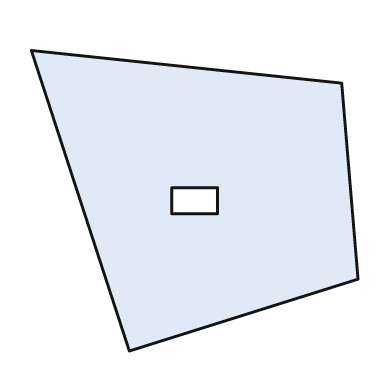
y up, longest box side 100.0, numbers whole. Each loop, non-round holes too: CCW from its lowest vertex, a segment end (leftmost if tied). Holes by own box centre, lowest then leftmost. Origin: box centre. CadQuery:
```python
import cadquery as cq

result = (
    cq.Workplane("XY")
    .moveTo(-20.0, -46.0)
    .lineTo(50.0, -24.0)
    .lineTo(45.0, 36.0)
    .lineTo(-50.0, 46.0)
    .close()
    .moveTo(-7.0, -4.0)
    .lineTo(7.0, -4.0)
    .lineTo(7.0, 4.0)
    .lineTo(-7.0, 4.0)
    .close()
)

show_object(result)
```